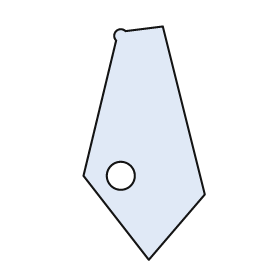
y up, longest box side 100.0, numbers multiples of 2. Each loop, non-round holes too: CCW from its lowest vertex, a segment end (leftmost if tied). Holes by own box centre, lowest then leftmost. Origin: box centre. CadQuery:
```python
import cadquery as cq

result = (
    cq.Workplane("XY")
    .moveTo(2.0, -50.0)
    .lineTo(26.0, -22.0)
    .lineTo(8.0, 50.0)
    .lineTo(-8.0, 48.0)
    .threePointArc((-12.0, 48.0), (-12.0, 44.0))
    .lineTo(-26.0, -14.0)
    .close()
    .moveTo(-10.0, -14.0)
    .circle(6.0)
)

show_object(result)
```